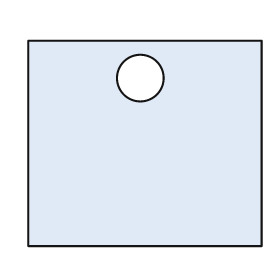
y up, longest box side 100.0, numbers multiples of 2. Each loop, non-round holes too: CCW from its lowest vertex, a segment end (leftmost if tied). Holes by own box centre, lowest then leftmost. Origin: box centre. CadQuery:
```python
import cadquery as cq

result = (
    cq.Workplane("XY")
    .moveTo(-50.0, -44.0)
    .lineTo(50.0, -44.0)
    .lineTo(50.0, 44.0)
    .lineTo(-50.0, 44.0)
    .close()
    .moveTo(-2.0, 28.0)
    .circle(10.0)
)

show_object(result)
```